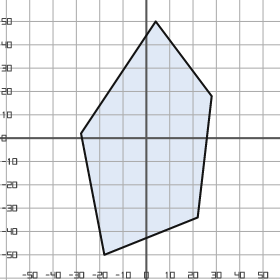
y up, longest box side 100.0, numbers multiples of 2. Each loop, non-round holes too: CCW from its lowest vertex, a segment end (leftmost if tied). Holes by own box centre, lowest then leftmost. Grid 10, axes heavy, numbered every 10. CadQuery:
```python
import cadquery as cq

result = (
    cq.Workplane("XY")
    .moveTo(-18.0, -50.0)
    .lineTo(22.0, -34.0)
    .lineTo(28.0, 18.0)
    .lineTo(4.0, 50.0)
    .lineTo(-28.0, 2.0)
    .close()
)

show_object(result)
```